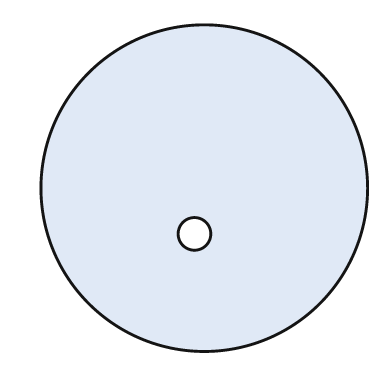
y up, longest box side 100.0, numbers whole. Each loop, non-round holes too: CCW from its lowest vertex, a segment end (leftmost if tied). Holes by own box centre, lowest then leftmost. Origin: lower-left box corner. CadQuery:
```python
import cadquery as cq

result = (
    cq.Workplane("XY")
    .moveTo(50.0, 50.0)
    .circle(50.0)
    .moveTo(47.0, 36.0)
    .circle(5.0)
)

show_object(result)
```